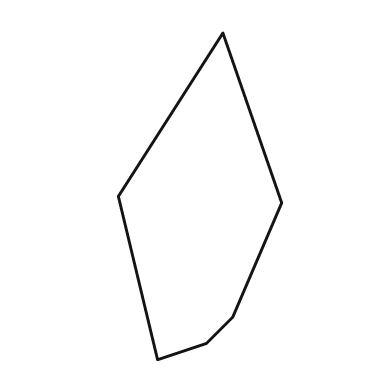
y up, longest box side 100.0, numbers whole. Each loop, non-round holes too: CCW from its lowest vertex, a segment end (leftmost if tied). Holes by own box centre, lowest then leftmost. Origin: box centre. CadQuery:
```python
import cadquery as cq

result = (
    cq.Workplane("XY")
    .moveTo(-13.0, -50.0)
    .lineTo(2.0, -45.0)
    .lineTo(10.0, -37.0)
    .lineTo(25.0, -2.0)
    .lineTo(7.0, 50.0)
    .lineTo(-25.0, 0.0)
    .close()
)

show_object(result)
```